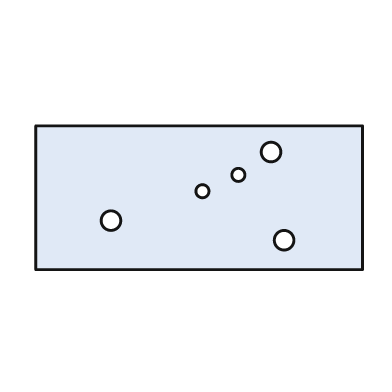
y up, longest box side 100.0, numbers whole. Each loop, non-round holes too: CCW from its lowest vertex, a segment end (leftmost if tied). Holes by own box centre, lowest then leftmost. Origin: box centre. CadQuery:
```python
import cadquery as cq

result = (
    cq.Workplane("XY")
    .moveTo(-50.0, -22.0)
    .lineTo(50.0, -22.0)
    .lineTo(50.0, 22.0)
    .lineTo(-50.0, 22.0)
    .close()
    .moveTo(26.0, -13.0)
    .circle(3.0)
    .moveTo(-27.0, -7.0)
    .circle(3.0)
    .moveTo(1.0, 2.0)
    .circle(2.0)
    .moveTo(12.0, 7.0)
    .circle(2.0)
    .moveTo(22.0, 14.0)
    .circle(3.0)
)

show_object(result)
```